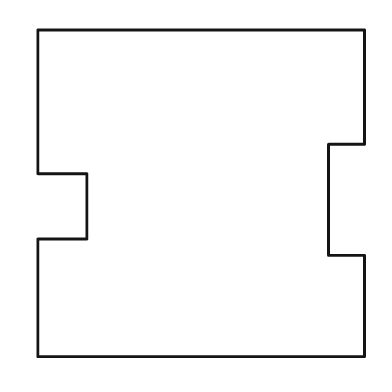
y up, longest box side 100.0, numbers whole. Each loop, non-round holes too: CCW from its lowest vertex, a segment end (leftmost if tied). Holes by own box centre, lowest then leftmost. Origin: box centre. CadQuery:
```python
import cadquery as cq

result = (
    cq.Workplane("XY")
    .moveTo(-50.0, -50.0)
    .lineTo(50.0, -50.0)
    .lineTo(50.0, -19.0)
    .lineTo(39.0, -19.0)
    .lineTo(39.0, 15.0)
    .lineTo(50.0, 15.0)
    .lineTo(50.0, 50.0)
    .lineTo(-50.0, 50.0)
    .lineTo(-50.0, 6.0)
    .lineTo(-35.0, 6.0)
    .lineTo(-35.0, -14.0)
    .lineTo(-50.0, -14.0)
    .close()
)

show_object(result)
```